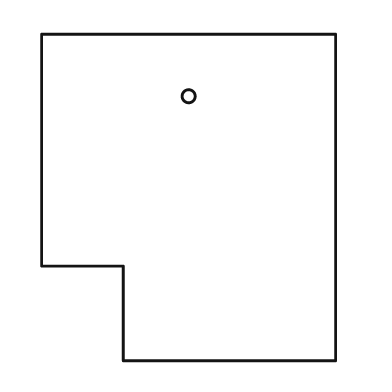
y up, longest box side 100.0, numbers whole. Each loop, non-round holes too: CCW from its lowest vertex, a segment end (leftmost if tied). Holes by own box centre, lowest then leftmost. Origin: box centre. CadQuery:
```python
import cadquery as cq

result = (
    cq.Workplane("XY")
    .moveTo(-20.0, -50.0)
    .lineTo(45.0, -50.0)
    .lineTo(45.0, 50.0)
    .lineTo(-45.0, 50.0)
    .lineTo(-45.0, -21.0)
    .lineTo(-20.0, -21.0)
    .close()
    .moveTo(0.0, 31.0)
    .circle(2.0)
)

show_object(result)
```